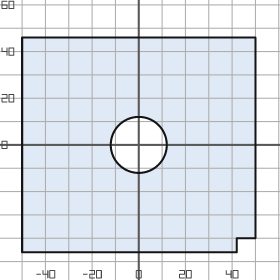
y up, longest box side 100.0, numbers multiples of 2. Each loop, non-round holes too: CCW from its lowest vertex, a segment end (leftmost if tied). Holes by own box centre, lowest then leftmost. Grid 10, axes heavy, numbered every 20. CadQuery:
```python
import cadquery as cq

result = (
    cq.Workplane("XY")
    .moveTo(-50.0, -46.0)
    .lineTo(42.0, -46.0)
    .lineTo(42.0, -40.0)
    .lineTo(50.0, -40.0)
    .lineTo(50.0, 46.0)
    .lineTo(-50.0, 46.0)
    .close()
    .moveTo(0.0, 0.0)
    .circle(12.0)
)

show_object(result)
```